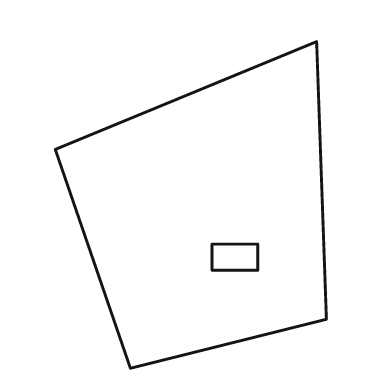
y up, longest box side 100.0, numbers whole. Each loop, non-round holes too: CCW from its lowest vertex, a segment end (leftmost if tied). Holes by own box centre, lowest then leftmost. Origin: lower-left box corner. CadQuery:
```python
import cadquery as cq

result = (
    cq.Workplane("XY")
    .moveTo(23.0, 0.0)
    .lineTo(83.0, 15.0)
    .lineTo(80.0, 100.0)
    .lineTo(0.0, 67.0)
    .close()
    .moveTo(48.0, 30.0)
    .lineTo(62.0, 30.0)
    .lineTo(62.0, 38.0)
    .lineTo(48.0, 38.0)
    .close()
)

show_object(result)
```